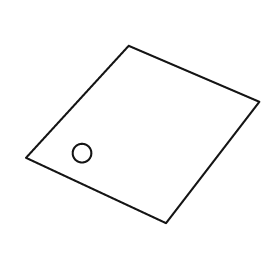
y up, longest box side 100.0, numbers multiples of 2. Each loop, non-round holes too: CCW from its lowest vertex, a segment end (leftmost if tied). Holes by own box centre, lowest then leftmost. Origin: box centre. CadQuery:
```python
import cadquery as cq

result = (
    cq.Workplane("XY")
    .moveTo(10.0, -38.0)
    .lineTo(50.0, 14.0)
    .lineTo(-6.0, 38.0)
    .lineTo(-50.0, -10.0)
    .close()
    .moveTo(-26.0, -8.0)
    .circle(4.0)
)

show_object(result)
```